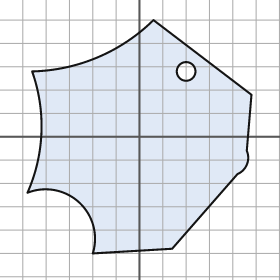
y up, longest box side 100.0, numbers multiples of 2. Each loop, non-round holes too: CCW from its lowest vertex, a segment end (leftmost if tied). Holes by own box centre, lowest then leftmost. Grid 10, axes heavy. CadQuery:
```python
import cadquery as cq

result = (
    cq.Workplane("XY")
    .moveTo(-20.0, -50.0)
    .lineTo(14.0, -48.0)
    .lineTo(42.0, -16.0)
    .threePointArc((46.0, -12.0), (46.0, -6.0))
    .lineTo(48.0, 18.0)
    .lineTo(6.0, 50.0)
    .threePointArc((-18.0, 34.0), (-46.0, 28.0))
    .threePointArc((-42.0, 2.0), (-48.0, -24.0))
    .threePointArc((-26.0, -28.0), (-20.0, -50.0))
    .close()
    .moveTo(20.0, 28.0)
    .circle(4.0)
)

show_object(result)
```